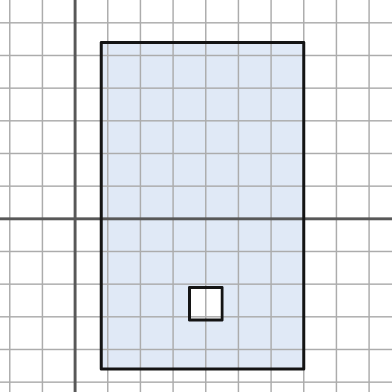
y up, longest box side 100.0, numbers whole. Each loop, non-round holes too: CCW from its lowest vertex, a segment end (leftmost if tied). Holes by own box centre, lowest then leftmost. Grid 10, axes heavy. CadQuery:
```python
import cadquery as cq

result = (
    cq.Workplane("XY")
    .moveTo(8.0, -46.0)
    .lineTo(70.0, -46.0)
    .lineTo(70.0, 54.0)
    .lineTo(8.0, 54.0)
    .close()
    .moveTo(35.0, -31.0)
    .lineTo(45.0, -31.0)
    .lineTo(45.0, -21.0)
    .lineTo(35.0, -21.0)
    .close()
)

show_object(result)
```